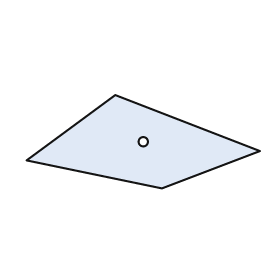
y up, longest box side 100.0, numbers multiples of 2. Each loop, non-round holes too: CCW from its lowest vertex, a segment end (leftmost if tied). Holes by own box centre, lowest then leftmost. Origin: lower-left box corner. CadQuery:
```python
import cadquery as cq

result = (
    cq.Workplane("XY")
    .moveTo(58.0, 0.0)
    .lineTo(100.0, 16.0)
    .lineTo(38.0, 40.0)
    .lineTo(0.0, 12.0)
    .close()
    .moveTo(50.0, 20.0)
    .circle(2.0)
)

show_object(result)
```